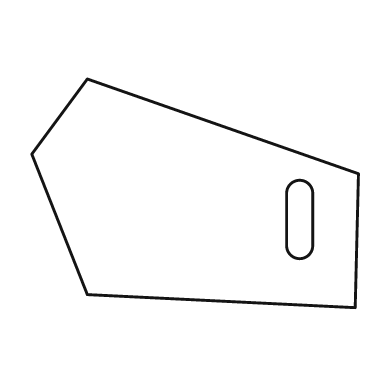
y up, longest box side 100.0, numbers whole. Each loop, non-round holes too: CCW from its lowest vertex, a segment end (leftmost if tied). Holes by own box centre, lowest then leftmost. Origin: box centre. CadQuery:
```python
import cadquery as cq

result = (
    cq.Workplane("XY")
    .moveTo(49.0, -35.0)
    .lineTo(50.0, 6.0)
    .lineTo(-33.0, 35.0)
    .lineTo(-50.0, 12.0)
    .lineTo(-33.0, -31.0)
    .close()
    .moveTo(28.0, -16.0)
    .threePointArc((32.0, -20.0), (36.0, -16.0))
    .lineTo(36.0, 0.0)
    .threePointArc((32.0, 4.0), (28.0, 0.0))
    .close()
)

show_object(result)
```